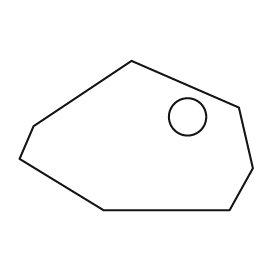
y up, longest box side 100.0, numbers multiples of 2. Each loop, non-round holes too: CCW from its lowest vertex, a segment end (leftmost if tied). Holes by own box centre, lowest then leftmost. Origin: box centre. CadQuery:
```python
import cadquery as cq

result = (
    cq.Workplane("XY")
    .moveTo(-14.0, -32.0)
    .lineTo(40.0, -32.0)
    .lineTo(50.0, -14.0)
    .lineTo(44.0, 12.0)
    .lineTo(-2.0, 32.0)
    .lineTo(-44.0, 4.0)
    .lineTo(-50.0, -10.0)
    .close()
    .moveTo(22.0, 8.0)
    .circle(8.0)
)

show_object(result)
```